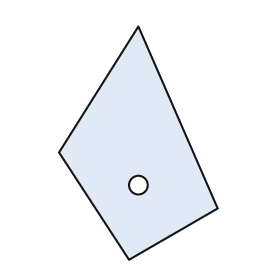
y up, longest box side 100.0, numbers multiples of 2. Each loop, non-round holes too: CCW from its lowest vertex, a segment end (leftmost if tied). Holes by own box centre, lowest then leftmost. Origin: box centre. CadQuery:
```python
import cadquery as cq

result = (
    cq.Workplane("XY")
    .moveTo(-4.0, -50.0)
    .lineTo(34.0, -28.0)
    .lineTo(0.0, 50.0)
    .lineTo(-34.0, -4.0)
    .close()
    .moveTo(0.0, -18.0)
    .circle(4.0)
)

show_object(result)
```